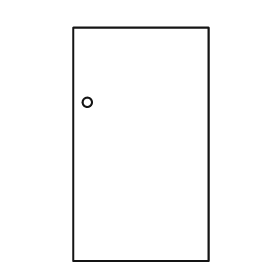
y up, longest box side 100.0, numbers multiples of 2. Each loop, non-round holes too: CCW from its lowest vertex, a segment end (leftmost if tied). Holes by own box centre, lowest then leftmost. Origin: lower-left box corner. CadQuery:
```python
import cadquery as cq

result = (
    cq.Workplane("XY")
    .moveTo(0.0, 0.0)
    .lineTo(58.0, 0.0)
    .lineTo(58.0, 100.0)
    .lineTo(0.0, 100.0)
    .close()
    .moveTo(6.0, 68.0)
    .circle(2.0)
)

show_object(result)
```